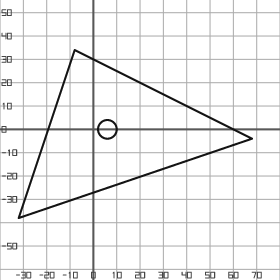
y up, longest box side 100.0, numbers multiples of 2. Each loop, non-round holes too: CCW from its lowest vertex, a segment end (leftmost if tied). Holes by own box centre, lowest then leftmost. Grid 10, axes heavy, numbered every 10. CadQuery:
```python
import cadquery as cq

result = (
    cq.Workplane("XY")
    .moveTo(-32.0, -38.0)
    .lineTo(68.0, -4.0)
    .lineTo(-8.0, 34.0)
    .close()
    .moveTo(6.0, 0.0)
    .circle(4.0)
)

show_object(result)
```